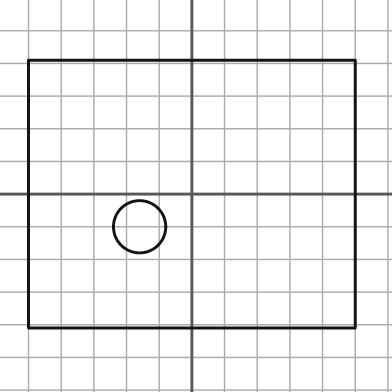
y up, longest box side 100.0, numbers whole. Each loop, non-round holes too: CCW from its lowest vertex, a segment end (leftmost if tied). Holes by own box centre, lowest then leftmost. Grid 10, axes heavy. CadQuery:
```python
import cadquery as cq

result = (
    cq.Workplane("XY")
    .moveTo(-50.0, -41.0)
    .lineTo(50.0, -41.0)
    .lineTo(50.0, 41.0)
    .lineTo(-50.0, 41.0)
    .close()
    .moveTo(-16.0, -10.0)
    .circle(8.0)
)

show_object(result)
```